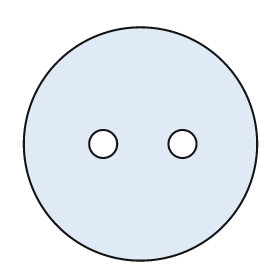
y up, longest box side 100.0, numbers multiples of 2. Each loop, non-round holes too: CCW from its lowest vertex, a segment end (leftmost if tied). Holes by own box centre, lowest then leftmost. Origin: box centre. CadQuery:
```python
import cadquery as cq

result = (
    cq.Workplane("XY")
    .moveTo(0.0, 0.0)
    .circle(50.0)
    .moveTo(-16.0, 0.0)
    .circle(6.0)
    .moveTo(18.0, 0.0)
    .circle(6.0)
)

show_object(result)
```